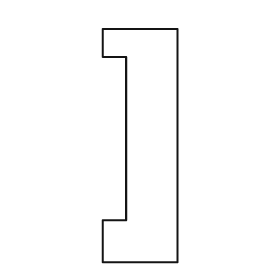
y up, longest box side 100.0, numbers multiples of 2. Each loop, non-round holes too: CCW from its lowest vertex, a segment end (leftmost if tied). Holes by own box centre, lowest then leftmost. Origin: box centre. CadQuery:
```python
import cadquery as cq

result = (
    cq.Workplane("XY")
    .moveTo(-16.0, -50.0)
    .lineTo(16.0, -50.0)
    .lineTo(16.0, 50.0)
    .lineTo(-16.0, 50.0)
    .lineTo(-16.0, 38.0)
    .lineTo(-6.0, 38.0)
    .lineTo(-6.0, -32.0)
    .lineTo(-16.0, -32.0)
    .close()
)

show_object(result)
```